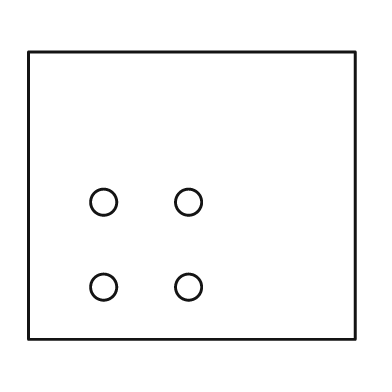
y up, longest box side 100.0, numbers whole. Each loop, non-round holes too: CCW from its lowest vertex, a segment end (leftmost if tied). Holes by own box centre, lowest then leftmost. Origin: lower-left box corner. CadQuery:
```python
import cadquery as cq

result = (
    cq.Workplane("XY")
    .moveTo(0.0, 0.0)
    .lineTo(100.0, 0.0)
    .lineTo(100.0, 88.0)
    .lineTo(0.0, 88.0)
    .close()
    .moveTo(23.0, 16.0)
    .circle(4.0)
    .moveTo(49.0, 16.0)
    .circle(4.0)
    .moveTo(23.0, 42.0)
    .circle(4.0)
    .moveTo(49.0, 42.0)
    .circle(4.0)
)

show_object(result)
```